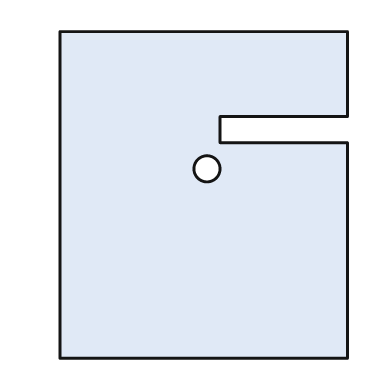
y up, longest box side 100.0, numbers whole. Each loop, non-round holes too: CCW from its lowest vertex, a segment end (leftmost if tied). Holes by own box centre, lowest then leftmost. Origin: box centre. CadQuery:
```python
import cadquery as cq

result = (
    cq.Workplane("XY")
    .moveTo(-44.0, -50.0)
    .lineTo(44.0, -50.0)
    .lineTo(44.0, 16.0)
    .lineTo(5.0, 16.0)
    .lineTo(5.0, 24.0)
    .lineTo(44.0, 24.0)
    .lineTo(44.0, 50.0)
    .lineTo(-44.0, 50.0)
    .close()
    .moveTo(1.0, 8.0)
    .circle(4.0)
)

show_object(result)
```